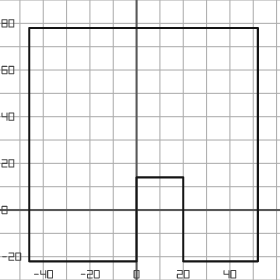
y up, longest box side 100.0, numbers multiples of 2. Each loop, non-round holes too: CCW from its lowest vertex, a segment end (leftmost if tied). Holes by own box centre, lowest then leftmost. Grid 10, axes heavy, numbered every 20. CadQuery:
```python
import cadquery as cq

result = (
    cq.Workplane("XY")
    .moveTo(-46.0, -22.0)
    .lineTo(0.0, -22.0)
    .lineTo(0.0, 14.0)
    .lineTo(20.0, 14.0)
    .lineTo(20.0, -22.0)
    .lineTo(52.0, -22.0)
    .lineTo(52.0, 78.0)
    .lineTo(-46.0, 78.0)
    .close()
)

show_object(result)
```